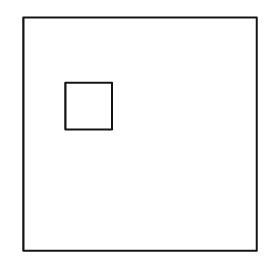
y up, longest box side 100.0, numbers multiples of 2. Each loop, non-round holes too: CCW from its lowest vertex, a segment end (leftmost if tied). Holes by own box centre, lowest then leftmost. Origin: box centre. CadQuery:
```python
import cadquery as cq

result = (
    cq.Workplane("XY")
    .moveTo(-50.0, -50.0)
    .lineTo(50.0, -50.0)
    .lineTo(50.0, 50.0)
    .lineTo(-50.0, 50.0)
    .close()
    .moveTo(-32.0, 2.0)
    .lineTo(-12.0, 2.0)
    .lineTo(-12.0, 22.0)
    .lineTo(-32.0, 22.0)
    .close()
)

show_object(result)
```